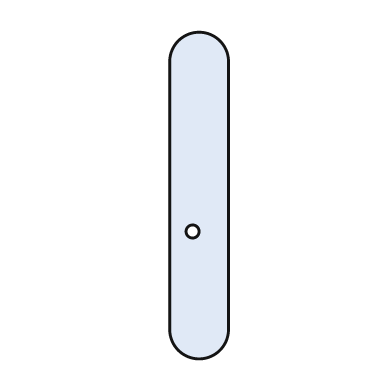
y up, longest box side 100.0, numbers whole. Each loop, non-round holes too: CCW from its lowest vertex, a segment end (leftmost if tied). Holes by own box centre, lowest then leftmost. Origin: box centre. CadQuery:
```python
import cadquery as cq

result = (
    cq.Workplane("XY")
    .moveTo(-9.0, -41.0)
    .threePointArc((0.0, -50.0), (9.0, -41.0))
    .lineTo(9.0, 41.0)
    .threePointArc((0.0, 50.0), (-9.0, 41.0))
    .close()
    .moveTo(-2.0, -11.0)
    .circle(2.0)
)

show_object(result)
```